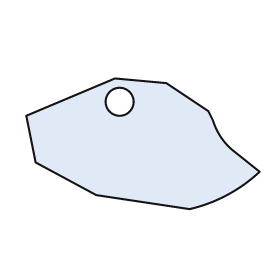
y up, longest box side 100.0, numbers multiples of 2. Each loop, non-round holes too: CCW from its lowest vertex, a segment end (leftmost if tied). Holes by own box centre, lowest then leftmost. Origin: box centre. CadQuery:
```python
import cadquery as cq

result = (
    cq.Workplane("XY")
    .moveTo(20.0, -28.0)
    .threePointArc((36.0, -22.0), (50.0, -12.0))
    .lineTo(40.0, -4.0)
    .threePointArc((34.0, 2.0), (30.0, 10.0))
    .lineTo(28.0, 14.0)
    .lineTo(10.0, 26.0)
    .lineTo(-12.0, 28.0)
    .lineTo(-50.0, 12.0)
    .lineTo(-46.0, -8.0)
    .lineTo(-20.0, -22.0)
    .close()
    .moveTo(-10.0, 18.0)
    .circle(6.0)
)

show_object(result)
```